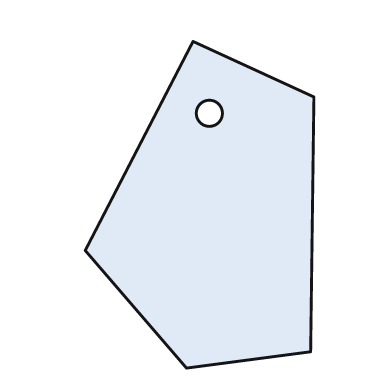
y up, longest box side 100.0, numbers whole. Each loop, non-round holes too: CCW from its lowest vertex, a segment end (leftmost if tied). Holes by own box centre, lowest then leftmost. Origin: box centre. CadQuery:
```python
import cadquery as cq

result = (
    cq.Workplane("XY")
    .moveTo(-4.0, -50.0)
    .lineTo(34.0, -45.0)
    .lineTo(35.0, 33.0)
    .lineTo(-2.0, 50.0)
    .lineTo(-35.0, -14.0)
    .close()
    .moveTo(3.0, 28.0)
    .circle(4.0)
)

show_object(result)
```